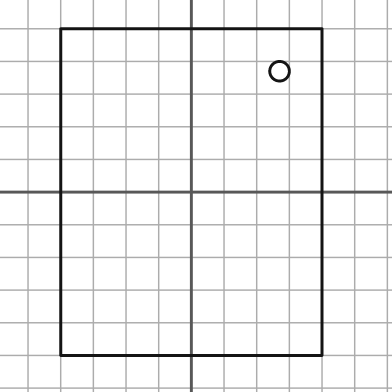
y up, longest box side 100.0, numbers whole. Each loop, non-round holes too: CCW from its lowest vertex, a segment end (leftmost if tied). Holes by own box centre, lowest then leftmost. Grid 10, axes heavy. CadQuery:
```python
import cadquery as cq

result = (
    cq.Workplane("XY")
    .moveTo(-40.0, -50.0)
    .lineTo(40.0, -50.0)
    .lineTo(40.0, 50.0)
    .lineTo(-40.0, 50.0)
    .close()
    .moveTo(27.0, 37.0)
    .circle(3.0)
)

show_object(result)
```